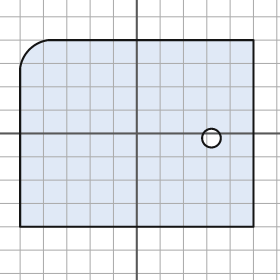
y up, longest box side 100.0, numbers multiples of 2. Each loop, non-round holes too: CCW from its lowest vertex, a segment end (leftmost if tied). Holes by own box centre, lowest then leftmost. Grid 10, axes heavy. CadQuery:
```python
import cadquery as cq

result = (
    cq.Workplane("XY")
    .moveTo(-50.0, -40.0)
    .lineTo(50.0, -40.0)
    .lineTo(50.0, 40.0)
    .lineTo(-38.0, 40.0)
    .threePointArc((-46.0, 36.0), (-50.0, 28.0))
    .close()
    .moveTo(32.0, -2.0)
    .circle(4.0)
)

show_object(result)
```